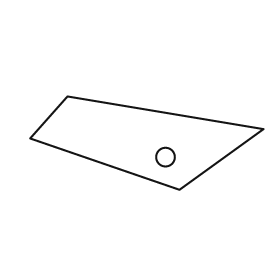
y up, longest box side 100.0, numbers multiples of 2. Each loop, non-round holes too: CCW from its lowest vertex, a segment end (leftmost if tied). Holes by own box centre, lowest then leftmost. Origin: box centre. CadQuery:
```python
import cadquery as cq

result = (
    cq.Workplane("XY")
    .moveTo(14.0, -20.0)
    .lineTo(50.0, 6.0)
    .lineTo(-34.0, 20.0)
    .lineTo(-50.0, 2.0)
    .close()
    .moveTo(8.0, -6.0)
    .circle(4.0)
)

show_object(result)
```